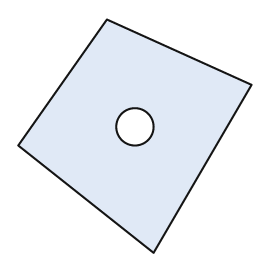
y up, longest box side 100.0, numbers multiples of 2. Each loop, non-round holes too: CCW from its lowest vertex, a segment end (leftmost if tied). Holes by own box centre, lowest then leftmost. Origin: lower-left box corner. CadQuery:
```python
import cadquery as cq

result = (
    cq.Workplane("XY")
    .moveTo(58.0, 0.0)
    .lineTo(100.0, 72.0)
    .lineTo(38.0, 100.0)
    .lineTo(0.0, 46.0)
    .close()
    .moveTo(50.0, 54.0)
    .circle(8.0)
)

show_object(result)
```